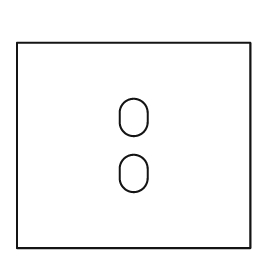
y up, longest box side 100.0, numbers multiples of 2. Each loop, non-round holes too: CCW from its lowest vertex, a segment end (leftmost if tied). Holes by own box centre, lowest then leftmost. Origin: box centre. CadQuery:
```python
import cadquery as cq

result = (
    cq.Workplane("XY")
    .moveTo(-50.0, -44.0)
    .lineTo(50.0, -44.0)
    .lineTo(50.0, 44.0)
    .lineTo(-50.0, 44.0)
    .close()
    .moveTo(-6.0, -14.0)
    .threePointArc((0.0, -20.0), (6.0, -14.0))
    .lineTo(6.0, -10.0)
    .threePointArc((0.0, -4.0), (-6.0, -10.0))
    .close()
    .moveTo(-6.0, 10.0)
    .threePointArc((0.0, 4.0), (6.0, 10.0))
    .lineTo(6.0, 14.0)
    .threePointArc((0.0, 20.0), (-6.0, 14.0))
    .close()
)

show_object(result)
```